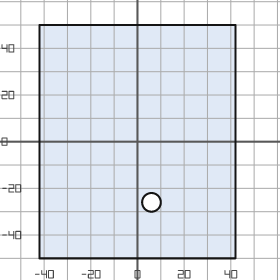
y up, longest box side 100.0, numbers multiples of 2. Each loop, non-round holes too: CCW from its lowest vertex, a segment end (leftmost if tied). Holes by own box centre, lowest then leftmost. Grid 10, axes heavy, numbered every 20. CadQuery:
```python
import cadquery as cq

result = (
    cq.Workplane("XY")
    .moveTo(-42.0, -50.0)
    .lineTo(42.0, -50.0)
    .lineTo(42.0, 50.0)
    .lineTo(-42.0, 50.0)
    .close()
    .moveTo(6.0, -26.0)
    .circle(4.0)
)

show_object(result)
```